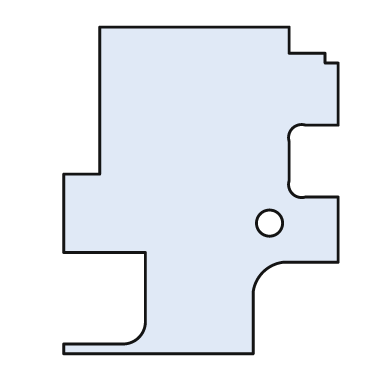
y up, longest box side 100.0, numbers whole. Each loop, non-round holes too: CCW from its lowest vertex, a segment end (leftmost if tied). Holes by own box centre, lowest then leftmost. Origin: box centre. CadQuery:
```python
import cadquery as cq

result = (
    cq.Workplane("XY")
    .moveTo(-42.0, -50.0)
    .lineTo(16.0, -50.0)
    .lineTo(16.0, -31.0)
    .threePointArc((19.0, -25.0), (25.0, -22.0))
    .lineTo(42.0, -22.0)
    .lineTo(42.0, -2.0)
    .lineTo(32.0, -2.0)
    .threePointArc((28.0, -1.0), (27.0, 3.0))
    .lineTo(27.0, 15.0)
    .threePointArc((28.0, 19.0), (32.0, 20.0))
    .lineTo(42.0, 20.0)
    .lineTo(42.0, 39.0)
    .lineTo(38.0, 39.0)
    .lineTo(38.0, 42.0)
    .lineTo(27.0, 42.0)
    .lineTo(27.0, 50.0)
    .lineTo(-31.0, 50.0)
    .lineTo(-31.0, 5.0)
    .lineTo(-42.0, 5.0)
    .lineTo(-42.0, -19.0)
    .lineTo(-17.0, -19.0)
    .lineTo(-17.0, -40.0)
    .threePointArc((-19.0, -45.0), (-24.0, -47.0))
    .lineTo(-42.0, -47.0)
    .close()
    .moveTo(21.0, -10.0)
    .circle(4.0)
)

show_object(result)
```